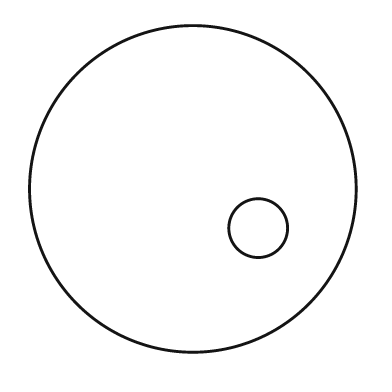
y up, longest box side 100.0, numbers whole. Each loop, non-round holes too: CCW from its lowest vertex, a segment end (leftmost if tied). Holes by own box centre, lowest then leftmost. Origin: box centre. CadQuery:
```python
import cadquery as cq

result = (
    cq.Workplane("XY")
    .moveTo(0.0, 0.0)
    .circle(50.0)
    .moveTo(20.0, -12.0)
    .circle(9.0)
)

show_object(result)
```